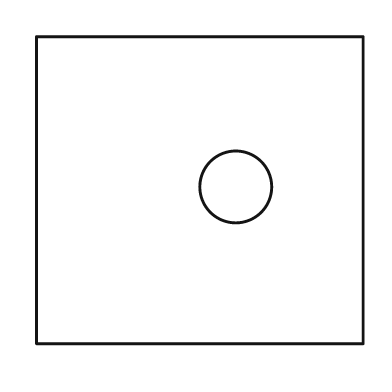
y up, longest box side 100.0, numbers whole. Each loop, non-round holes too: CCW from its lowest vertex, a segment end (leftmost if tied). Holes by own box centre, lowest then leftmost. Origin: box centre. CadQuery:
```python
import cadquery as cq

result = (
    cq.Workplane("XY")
    .moveTo(-50.0, -47.0)
    .lineTo(50.0, -47.0)
    .lineTo(50.0, 47.0)
    .lineTo(-50.0, 47.0)
    .close()
    .moveTo(11.0, 1.0)
    .circle(11.0)
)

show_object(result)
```